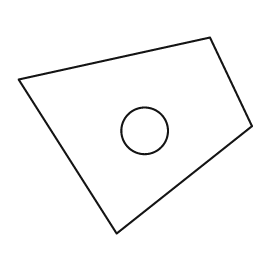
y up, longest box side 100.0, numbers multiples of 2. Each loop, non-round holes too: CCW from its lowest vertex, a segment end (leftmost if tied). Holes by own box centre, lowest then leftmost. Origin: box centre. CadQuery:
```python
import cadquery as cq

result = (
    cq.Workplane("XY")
    .moveTo(-8.0, -42.0)
    .lineTo(50.0, 4.0)
    .lineTo(32.0, 42.0)
    .lineTo(-50.0, 24.0)
    .close()
    .moveTo(4.0, 2.0)
    .circle(10.0)
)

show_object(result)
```